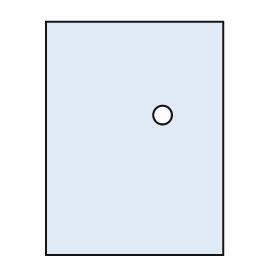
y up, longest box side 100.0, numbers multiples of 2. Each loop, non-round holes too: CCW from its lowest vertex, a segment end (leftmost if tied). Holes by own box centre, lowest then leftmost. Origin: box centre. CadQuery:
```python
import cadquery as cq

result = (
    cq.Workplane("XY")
    .moveTo(-38.0, -50.0)
    .lineTo(38.0, -50.0)
    .lineTo(38.0, 50.0)
    .lineTo(-38.0, 50.0)
    .close()
    .moveTo(12.0, 10.0)
    .circle(4.0)
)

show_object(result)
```